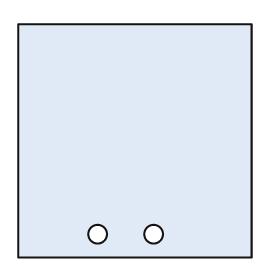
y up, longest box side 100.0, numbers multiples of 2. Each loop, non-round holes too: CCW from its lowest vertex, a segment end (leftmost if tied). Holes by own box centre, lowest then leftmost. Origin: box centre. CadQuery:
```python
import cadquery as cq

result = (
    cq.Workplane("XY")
    .moveTo(-50.0, -50.0)
    .lineTo(50.0, -50.0)
    .lineTo(50.0, 50.0)
    .lineTo(-50.0, 50.0)
    .close()
    .moveTo(-16.0, -40.0)
    .circle(4.0)
    .moveTo(8.0, -40.0)
    .circle(4.0)
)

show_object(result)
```